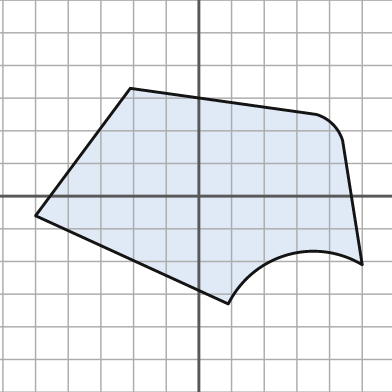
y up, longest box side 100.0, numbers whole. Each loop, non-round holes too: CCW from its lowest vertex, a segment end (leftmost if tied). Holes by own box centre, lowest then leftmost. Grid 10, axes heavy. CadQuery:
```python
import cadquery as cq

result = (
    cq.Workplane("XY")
    .moveTo(9.0, -33.0)
    .threePointArc((27.0, -18.0), (50.0, -21.0))
    .lineTo(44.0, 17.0)
    .threePointArc((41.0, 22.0), (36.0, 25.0))
    .lineTo(-21.0, 33.0)
    .lineTo(-50.0, -6.0)
    .close()
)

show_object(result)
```